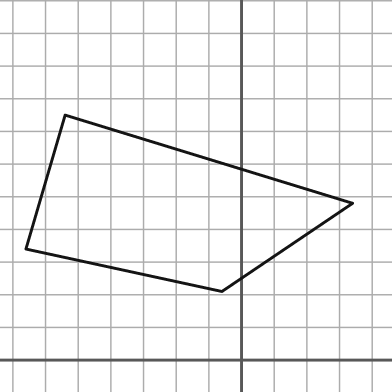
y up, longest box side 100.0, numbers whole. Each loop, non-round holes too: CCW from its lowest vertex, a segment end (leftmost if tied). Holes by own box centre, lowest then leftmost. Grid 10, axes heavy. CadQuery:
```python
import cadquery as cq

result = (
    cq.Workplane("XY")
    .moveTo(-6.0, 21.0)
    .lineTo(34.0, 48.0)
    .lineTo(-54.0, 75.0)
    .lineTo(-66.0, 34.0)
    .close()
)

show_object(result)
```